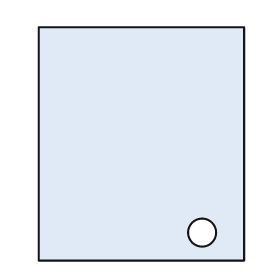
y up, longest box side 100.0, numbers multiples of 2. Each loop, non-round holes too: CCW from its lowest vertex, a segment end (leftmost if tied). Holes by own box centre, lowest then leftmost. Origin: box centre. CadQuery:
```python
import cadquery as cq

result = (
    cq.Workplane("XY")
    .moveTo(-44.0, -50.0)
    .lineTo(44.0, -50.0)
    .lineTo(44.0, 50.0)
    .lineTo(-44.0, 50.0)
    .close()
    .moveTo(26.0, -38.0)
    .circle(6.0)
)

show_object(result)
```